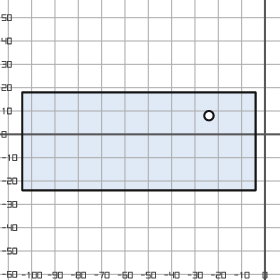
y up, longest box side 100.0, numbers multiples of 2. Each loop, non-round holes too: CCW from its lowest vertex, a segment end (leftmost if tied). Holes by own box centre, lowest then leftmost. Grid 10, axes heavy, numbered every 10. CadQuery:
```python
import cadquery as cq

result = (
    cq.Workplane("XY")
    .moveTo(-104.0, -24.0)
    .lineTo(-4.0, -24.0)
    .lineTo(-4.0, 18.0)
    .lineTo(-104.0, 18.0)
    .close()
    .moveTo(-24.0, 8.0)
    .circle(2.0)
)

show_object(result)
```